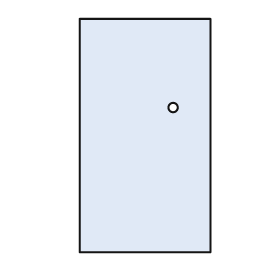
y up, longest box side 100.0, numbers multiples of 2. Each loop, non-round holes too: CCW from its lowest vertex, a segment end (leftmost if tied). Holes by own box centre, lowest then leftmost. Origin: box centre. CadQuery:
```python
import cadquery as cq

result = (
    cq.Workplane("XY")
    .moveTo(-28.0, -50.0)
    .lineTo(28.0, -50.0)
    .lineTo(28.0, 50.0)
    .lineTo(-28.0, 50.0)
    .close()
    .moveTo(12.0, 12.0)
    .circle(2.0)
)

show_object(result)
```